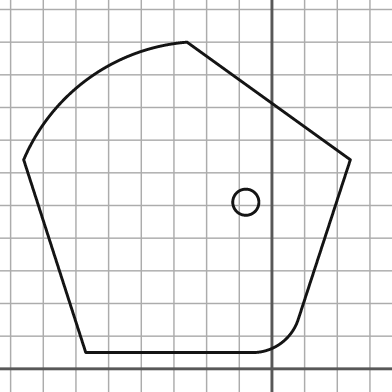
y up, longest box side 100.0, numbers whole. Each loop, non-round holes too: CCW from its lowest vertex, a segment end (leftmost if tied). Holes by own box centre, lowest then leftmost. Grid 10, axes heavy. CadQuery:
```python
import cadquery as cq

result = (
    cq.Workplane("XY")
    .moveTo(-57.0, 5.0)
    .lineTo(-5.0, 5.0)
    .threePointArc((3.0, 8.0), (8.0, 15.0))
    .lineTo(24.0, 64.0)
    .lineTo(-26.0, 100.0)
    .threePointArc((-56.0, 89.0), (-76.0, 64.0))
    .close()
    .moveTo(-8.0, 51.0)
    .circle(4.0)
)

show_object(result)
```